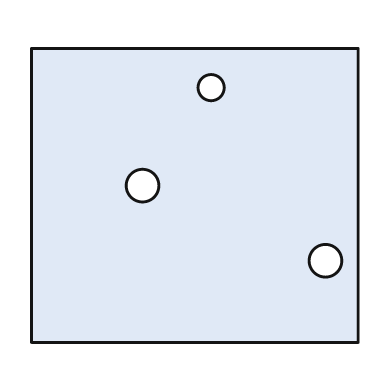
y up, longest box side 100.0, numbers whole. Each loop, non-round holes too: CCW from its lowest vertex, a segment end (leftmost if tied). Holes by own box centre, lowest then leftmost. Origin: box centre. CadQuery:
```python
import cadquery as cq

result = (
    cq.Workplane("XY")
    .moveTo(-50.0, -45.0)
    .lineTo(50.0, -45.0)
    .lineTo(50.0, 45.0)
    .lineTo(-50.0, 45.0)
    .close()
    .moveTo(40.0, -20.0)
    .circle(5.0)
    .moveTo(-16.0, 3.0)
    .circle(5.0)
    .moveTo(5.0, 33.0)
    .circle(4.0)
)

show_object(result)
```